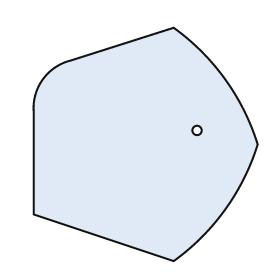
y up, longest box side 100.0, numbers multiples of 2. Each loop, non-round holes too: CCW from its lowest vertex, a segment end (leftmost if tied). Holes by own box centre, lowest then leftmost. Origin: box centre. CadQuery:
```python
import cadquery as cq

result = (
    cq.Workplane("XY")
    .moveTo(12.0, -50.0)
    .threePointArc((34.0, -28.0), (48.0, 0.0))
    .threePointArc((34.0, 28.0), (12.0, 50.0))
    .lineTo(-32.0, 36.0)
    .threePointArc((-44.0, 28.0), (-48.0, 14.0))
    .lineTo(-48.0, -30.0)
    .close()
    .moveTo(22.0, 6.0)
    .circle(2.0)
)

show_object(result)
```